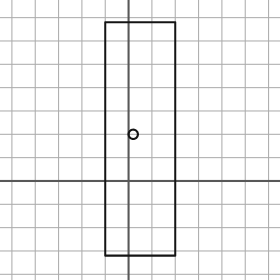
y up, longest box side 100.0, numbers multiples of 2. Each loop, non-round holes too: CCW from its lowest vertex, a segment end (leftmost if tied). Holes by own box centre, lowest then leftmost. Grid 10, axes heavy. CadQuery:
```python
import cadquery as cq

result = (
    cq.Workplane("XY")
    .moveTo(-10.0, -32.0)
    .lineTo(20.0, -32.0)
    .lineTo(20.0, 68.0)
    .lineTo(-10.0, 68.0)
    .close()
    .moveTo(2.0, 20.0)
    .circle(2.0)
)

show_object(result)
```